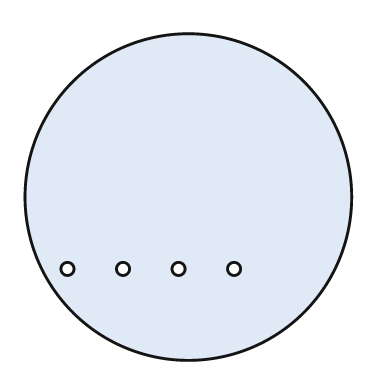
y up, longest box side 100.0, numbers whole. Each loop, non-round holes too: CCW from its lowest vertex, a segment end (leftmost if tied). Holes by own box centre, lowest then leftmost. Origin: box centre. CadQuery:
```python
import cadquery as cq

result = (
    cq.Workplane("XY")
    .moveTo(0.0, 0.0)
    .circle(50.0)
    .moveTo(-37.0, -22.0)
    .circle(2.0)
    .moveTo(-20.0, -22.0)
    .circle(2.0)
    .moveTo(-3.0, -22.0)
    .circle(2.0)
    .moveTo(14.0, -22.0)
    .circle(2.0)
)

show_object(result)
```